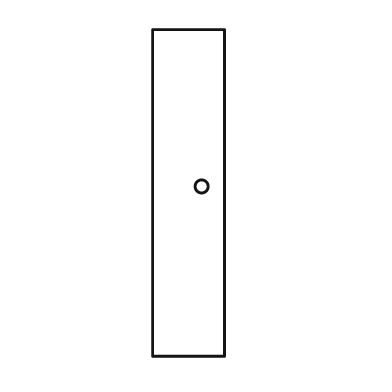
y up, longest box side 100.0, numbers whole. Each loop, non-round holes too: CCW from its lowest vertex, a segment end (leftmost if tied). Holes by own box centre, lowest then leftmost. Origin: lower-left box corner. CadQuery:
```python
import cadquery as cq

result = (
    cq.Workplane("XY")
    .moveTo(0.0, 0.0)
    .lineTo(22.0, 0.0)
    .lineTo(22.0, 100.0)
    .lineTo(0.0, 100.0)
    .close()
    .moveTo(15.0, 52.0)
    .circle(2.0)
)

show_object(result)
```